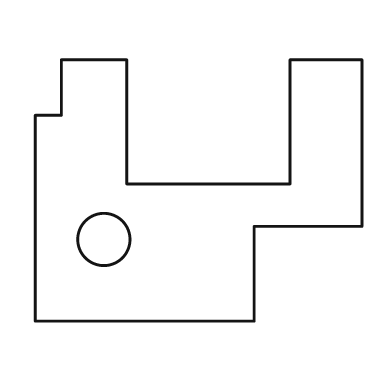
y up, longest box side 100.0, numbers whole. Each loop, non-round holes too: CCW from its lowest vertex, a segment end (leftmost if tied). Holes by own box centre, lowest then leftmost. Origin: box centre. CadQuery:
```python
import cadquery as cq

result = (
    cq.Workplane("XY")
    .moveTo(-50.0, -40.0)
    .lineTo(17.0, -40.0)
    .lineTo(17.0, -11.0)
    .lineTo(50.0, -11.0)
    .lineTo(50.0, 40.0)
    .lineTo(28.0, 40.0)
    .lineTo(28.0, 2.0)
    .lineTo(-22.0, 2.0)
    .lineTo(-22.0, 40.0)
    .lineTo(-42.0, 40.0)
    .lineTo(-42.0, 23.0)
    .lineTo(-50.0, 23.0)
    .close()
    .moveTo(-29.0, -15.0)
    .circle(8.0)
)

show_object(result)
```